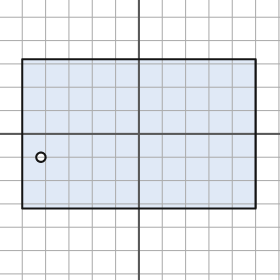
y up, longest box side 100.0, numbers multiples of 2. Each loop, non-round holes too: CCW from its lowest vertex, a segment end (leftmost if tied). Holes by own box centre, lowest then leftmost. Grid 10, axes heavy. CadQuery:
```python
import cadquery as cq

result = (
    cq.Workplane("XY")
    .moveTo(-50.0, -32.0)
    .lineTo(50.0, -32.0)
    .lineTo(50.0, 32.0)
    .lineTo(-50.0, 32.0)
    .close()
    .moveTo(-42.0, -10.0)
    .circle(2.0)
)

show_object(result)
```